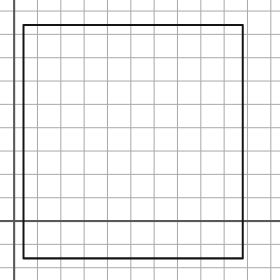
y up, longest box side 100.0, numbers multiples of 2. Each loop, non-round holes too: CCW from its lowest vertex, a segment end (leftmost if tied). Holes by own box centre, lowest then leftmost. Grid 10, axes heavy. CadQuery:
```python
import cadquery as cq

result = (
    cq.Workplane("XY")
    .moveTo(4.0, -16.0)
    .lineTo(98.0, -16.0)
    .lineTo(98.0, 84.0)
    .lineTo(4.0, 84.0)
    .close()
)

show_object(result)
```